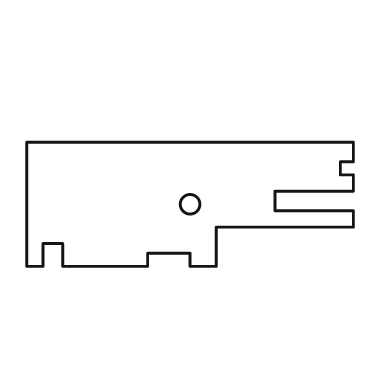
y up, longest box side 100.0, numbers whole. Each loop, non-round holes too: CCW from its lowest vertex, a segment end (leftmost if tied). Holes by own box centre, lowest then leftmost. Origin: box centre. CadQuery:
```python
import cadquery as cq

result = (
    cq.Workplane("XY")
    .moveTo(-50.0, -19.0)
    .lineTo(-45.0, -19.0)
    .lineTo(-45.0, -12.0)
    .lineTo(-39.0, -12.0)
    .lineTo(-39.0, -19.0)
    .lineTo(-13.0, -19.0)
    .lineTo(-13.0, -15.0)
    .lineTo(0.0, -15.0)
    .lineTo(0.0, -19.0)
    .lineTo(8.0, -19.0)
    .lineTo(8.0, -7.0)
    .lineTo(50.0, -7.0)
    .lineTo(50.0, -2.0)
    .lineTo(26.0, -2.0)
    .lineTo(26.0, 4.0)
    .lineTo(50.0, 4.0)
    .lineTo(50.0, 9.0)
    .lineTo(46.0, 9.0)
    .lineTo(46.0, 13.0)
    .lineTo(50.0, 13.0)
    .lineTo(50.0, 19.0)
    .lineTo(-50.0, 19.0)
    .close()
    .moveTo(0.0, 0.0)
    .circle(3.0)
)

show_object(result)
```